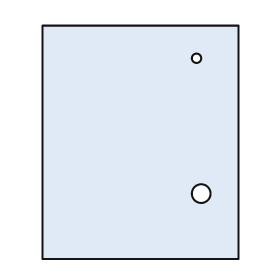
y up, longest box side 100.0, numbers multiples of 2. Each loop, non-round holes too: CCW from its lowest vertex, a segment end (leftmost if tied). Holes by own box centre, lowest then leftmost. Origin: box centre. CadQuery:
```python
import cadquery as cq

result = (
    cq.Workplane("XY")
    .moveTo(-42.0, -50.0)
    .lineTo(42.0, -50.0)
    .lineTo(42.0, 50.0)
    .lineTo(-42.0, 50.0)
    .close()
    .moveTo(26.0, -22.0)
    .circle(4.0)
    .moveTo(24.0, 36.0)
    .circle(2.0)
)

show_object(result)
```